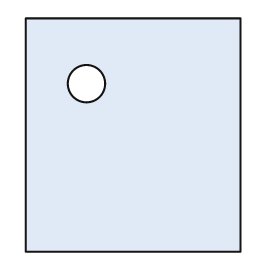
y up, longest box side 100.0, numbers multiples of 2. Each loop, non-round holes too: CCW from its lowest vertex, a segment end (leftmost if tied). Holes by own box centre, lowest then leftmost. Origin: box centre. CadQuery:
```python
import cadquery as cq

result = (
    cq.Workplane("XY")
    .moveTo(-46.0, -50.0)
    .lineTo(46.0, -50.0)
    .lineTo(46.0, 50.0)
    .lineTo(-46.0, 50.0)
    .close()
    .moveTo(-20.0, 22.0)
    .circle(8.0)
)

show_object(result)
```